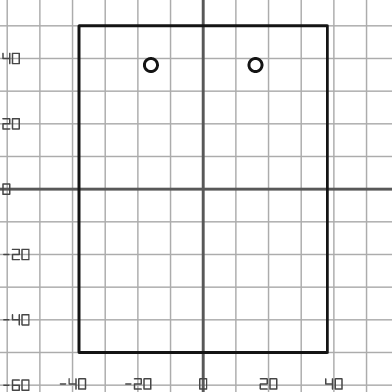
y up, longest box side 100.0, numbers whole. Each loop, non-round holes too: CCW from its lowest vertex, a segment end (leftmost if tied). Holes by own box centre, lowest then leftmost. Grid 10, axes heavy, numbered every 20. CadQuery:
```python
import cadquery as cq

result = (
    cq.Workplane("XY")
    .moveTo(-38.0, -50.0)
    .lineTo(38.0, -50.0)
    .lineTo(38.0, 50.0)
    .lineTo(-38.0, 50.0)
    .close()
    .moveTo(-16.0, 38.0)
    .circle(2.0)
    .moveTo(16.0, 38.0)
    .circle(2.0)
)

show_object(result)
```